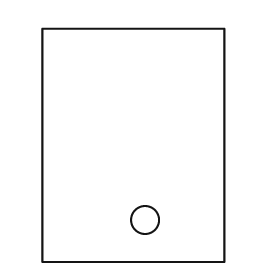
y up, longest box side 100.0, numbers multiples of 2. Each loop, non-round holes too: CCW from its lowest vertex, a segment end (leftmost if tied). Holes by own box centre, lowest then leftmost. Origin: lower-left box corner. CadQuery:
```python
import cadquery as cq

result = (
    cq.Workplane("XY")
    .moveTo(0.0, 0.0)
    .lineTo(78.0, 0.0)
    .lineTo(78.0, 100.0)
    .lineTo(0.0, 100.0)
    .close()
    .moveTo(44.0, 18.0)
    .circle(6.0)
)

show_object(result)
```